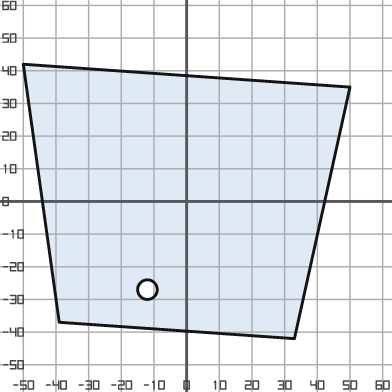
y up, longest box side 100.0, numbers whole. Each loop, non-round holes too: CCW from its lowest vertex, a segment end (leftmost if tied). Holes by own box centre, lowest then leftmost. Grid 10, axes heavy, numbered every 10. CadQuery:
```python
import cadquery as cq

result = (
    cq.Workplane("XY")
    .moveTo(33.0, -42.0)
    .lineTo(50.0, 35.0)
    .lineTo(-50.0, 42.0)
    .lineTo(-39.0, -37.0)
    .close()
    .moveTo(-12.0, -27.0)
    .circle(3.0)
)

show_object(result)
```